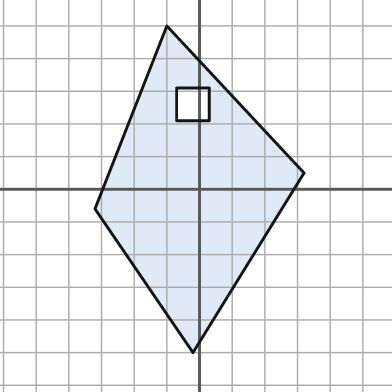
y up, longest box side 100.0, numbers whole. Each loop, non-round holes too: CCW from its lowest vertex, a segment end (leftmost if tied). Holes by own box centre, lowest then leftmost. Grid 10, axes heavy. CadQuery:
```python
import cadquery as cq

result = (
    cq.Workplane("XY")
    .moveTo(-2.0, -50.0)
    .lineTo(32.0, 5.0)
    .lineTo(-10.0, 50.0)
    .lineTo(-32.0, -6.0)
    .close()
    .moveTo(-7.0, 21.0)
    .lineTo(3.0, 21.0)
    .lineTo(3.0, 31.0)
    .lineTo(-7.0, 31.0)
    .close()
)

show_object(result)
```